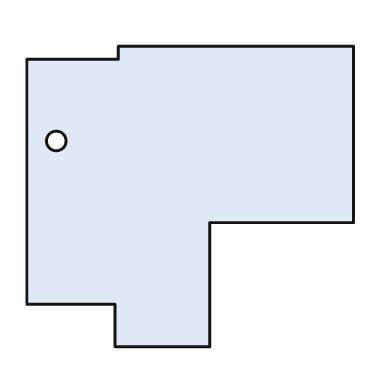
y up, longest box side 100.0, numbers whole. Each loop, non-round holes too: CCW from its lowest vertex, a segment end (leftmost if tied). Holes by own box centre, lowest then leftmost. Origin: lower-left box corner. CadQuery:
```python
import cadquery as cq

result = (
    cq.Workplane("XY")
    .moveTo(27.0, 0.0)
    .lineTo(56.0, 0.0)
    .lineTo(56.0, 38.0)
    .lineTo(100.0, 38.0)
    .lineTo(100.0, 92.0)
    .lineTo(28.0, 92.0)
    .lineTo(28.0, 88.0)
    .lineTo(0.0, 88.0)
    .lineTo(0.0, 13.0)
    .lineTo(27.0, 13.0)
    .close()
    .moveTo(9.0, 63.0)
    .circle(3.0)
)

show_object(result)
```